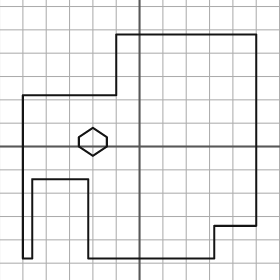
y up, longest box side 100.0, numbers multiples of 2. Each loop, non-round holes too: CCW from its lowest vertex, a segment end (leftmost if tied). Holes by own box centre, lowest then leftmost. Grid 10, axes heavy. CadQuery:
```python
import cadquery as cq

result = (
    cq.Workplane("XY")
    .moveTo(-50.0, -48.0)
    .lineTo(-46.0, -48.0)
    .lineTo(-46.0, -14.0)
    .lineTo(-22.0, -14.0)
    .lineTo(-22.0, -48.0)
    .lineTo(32.0, -48.0)
    .lineTo(32.0, -34.0)
    .lineTo(50.0, -34.0)
    .lineTo(50.0, 48.0)
    .lineTo(-10.0, 48.0)
    .lineTo(-10.0, 22.0)
    .lineTo(-50.0, 22.0)
    .close()
    .moveTo(-20.0, -4.0)
    .lineTo(-14.0, 0.0)
    .lineTo(-14.0, 4.0)
    .lineTo(-20.0, 8.0)
    .lineTo(-26.0, 4.0)
    .lineTo(-26.0, 0.0)
    .close()
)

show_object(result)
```